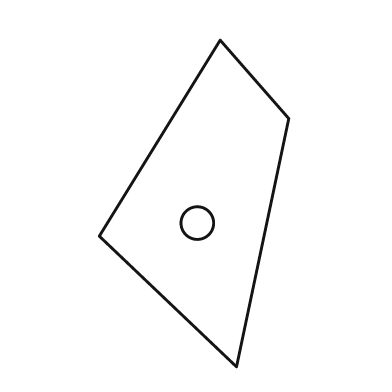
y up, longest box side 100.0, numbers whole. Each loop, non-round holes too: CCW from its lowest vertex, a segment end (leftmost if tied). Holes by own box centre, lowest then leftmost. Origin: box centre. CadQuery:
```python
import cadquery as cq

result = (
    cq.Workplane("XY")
    .moveTo(13.0, -50.0)
    .lineTo(29.0, 26.0)
    .lineTo(8.0, 50.0)
    .lineTo(-29.0, -10.0)
    .close()
    .moveTo(1.0, -6.0)
    .circle(5.0)
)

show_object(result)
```